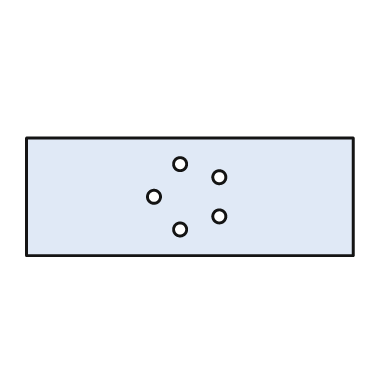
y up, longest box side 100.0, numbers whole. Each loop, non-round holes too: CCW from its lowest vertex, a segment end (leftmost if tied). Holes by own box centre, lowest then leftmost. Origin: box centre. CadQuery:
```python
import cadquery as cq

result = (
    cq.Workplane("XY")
    .moveTo(-50.0, -18.0)
    .lineTo(50.0, -18.0)
    .lineTo(50.0, 18.0)
    .lineTo(-50.0, 18.0)
    .close()
    .moveTo(-3.0, -10.0)
    .circle(2.0)
    .moveTo(9.0, -6.0)
    .circle(2.0)
    .moveTo(-11.0, 0.0)
    .circle(2.0)
    .moveTo(9.0, 6.0)
    .circle(2.0)
    .moveTo(-3.0, 10.0)
    .circle(2.0)
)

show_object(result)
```